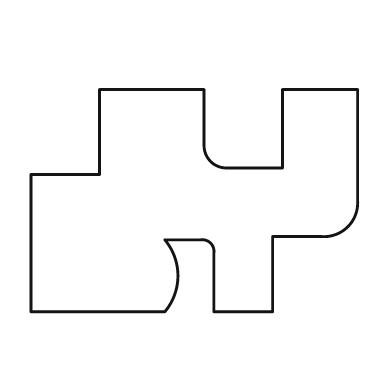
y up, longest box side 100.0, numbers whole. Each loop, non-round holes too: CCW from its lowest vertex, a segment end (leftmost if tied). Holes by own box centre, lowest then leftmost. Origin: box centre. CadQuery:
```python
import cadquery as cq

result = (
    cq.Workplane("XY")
    .moveTo(-50.0, -34.0)
    .lineTo(-9.0, -34.0)
    .threePointArc((-5.0, -23.0), (-9.0, -12.0))
    .lineTo(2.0, -12.0)
    .threePointArc((5.0, -13.0), (6.0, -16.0))
    .lineTo(6.0, -34.0)
    .lineTo(24.0, -34.0)
    .lineTo(24.0, -11.0)
    .lineTo(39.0, -11.0)
    .threePointArc((47.0, -8.0), (50.0, 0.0))
    .lineTo(50.0, 34.0)
    .lineTo(27.0, 34.0)
    .lineTo(27.0, 10.0)
    .lineTo(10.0, 10.0)
    .threePointArc((5.0, 12.0), (3.0, 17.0))
    .lineTo(3.0, 34.0)
    .lineTo(-29.0, 34.0)
    .lineTo(-29.0, 8.0)
    .lineTo(-50.0, 8.0)
    .close()
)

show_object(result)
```